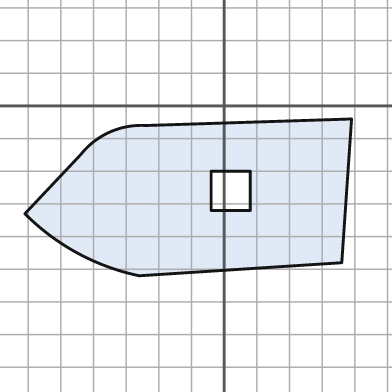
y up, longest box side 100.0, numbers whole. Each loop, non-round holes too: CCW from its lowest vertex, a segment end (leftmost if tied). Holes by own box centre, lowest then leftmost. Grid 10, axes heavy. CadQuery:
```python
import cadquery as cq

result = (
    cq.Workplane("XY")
    .moveTo(-26.0, -52.0)
    .lineTo(36.0, -48.0)
    .lineTo(39.0, -4.0)
    .lineTo(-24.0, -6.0)
    .threePointArc((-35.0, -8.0), (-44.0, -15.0))
    .lineTo(-61.0, -33.0)
    .threePointArc((-45.0, -45.0), (-26.0, -52.0))
    .close()
    .moveTo(-4.0, -32.0)
    .lineTo(8.0, -32.0)
    .lineTo(8.0, -20.0)
    .lineTo(-4.0, -20.0)
    .close()
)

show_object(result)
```